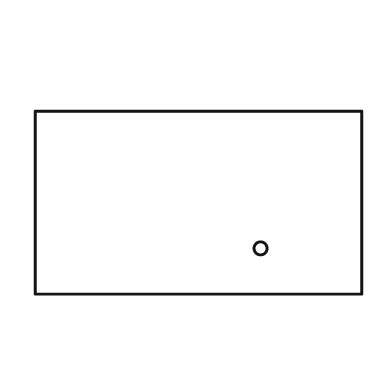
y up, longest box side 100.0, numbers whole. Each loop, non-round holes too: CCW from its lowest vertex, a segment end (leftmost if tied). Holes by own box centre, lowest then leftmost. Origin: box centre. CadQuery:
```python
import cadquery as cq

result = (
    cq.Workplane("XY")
    .moveTo(-50.0, -28.0)
    .lineTo(50.0, -28.0)
    .lineTo(50.0, 28.0)
    .lineTo(-50.0, 28.0)
    .close()
    .moveTo(19.0, -14.0)
    .circle(2.0)
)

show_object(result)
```